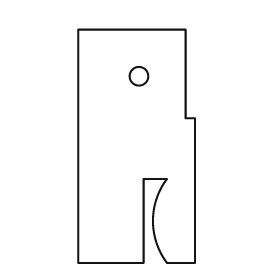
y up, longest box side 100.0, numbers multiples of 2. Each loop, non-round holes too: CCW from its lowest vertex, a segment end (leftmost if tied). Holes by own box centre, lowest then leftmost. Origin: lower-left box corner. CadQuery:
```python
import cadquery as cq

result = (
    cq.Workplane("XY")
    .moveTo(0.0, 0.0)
    .lineTo(28.0, 0.0)
    .lineTo(28.0, 36.0)
    .lineTo(38.0, 36.0)
    .threePointArc((32.0, 18.0), (38.0, 0.0))
    .lineTo(50.0, 0.0)
    .lineTo(50.0, 62.0)
    .lineTo(46.0, 62.0)
    .lineTo(46.0, 100.0)
    .lineTo(0.0, 100.0)
    .close()
    .moveTo(26.0, 80.0)
    .circle(4.0)
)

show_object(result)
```